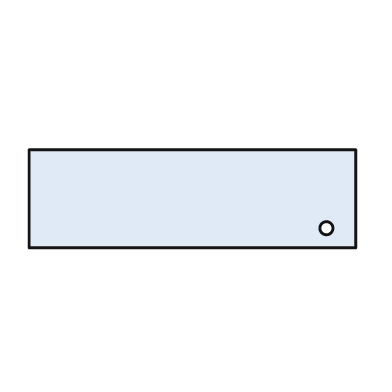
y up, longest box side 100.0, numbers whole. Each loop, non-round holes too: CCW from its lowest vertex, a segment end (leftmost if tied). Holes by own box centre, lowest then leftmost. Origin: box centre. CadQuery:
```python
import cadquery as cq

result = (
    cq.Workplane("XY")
    .moveTo(-50.0, -15.0)
    .lineTo(50.0, -15.0)
    .lineTo(50.0, 15.0)
    .lineTo(-50.0, 15.0)
    .close()
    .moveTo(41.0, -9.0)
    .circle(2.0)
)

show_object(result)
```